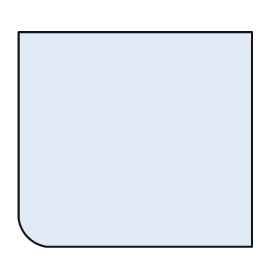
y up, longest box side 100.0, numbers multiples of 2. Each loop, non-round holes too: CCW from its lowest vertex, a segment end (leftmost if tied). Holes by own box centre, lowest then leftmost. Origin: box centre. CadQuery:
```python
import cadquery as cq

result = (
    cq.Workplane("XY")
    .moveTo(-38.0, -46.0)
    .lineTo(50.0, -46.0)
    .lineTo(50.0, 46.0)
    .lineTo(-50.0, 46.0)
    .lineTo(-50.0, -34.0)
    .threePointArc((-46.0, -42.0), (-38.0, -46.0))
    .close()
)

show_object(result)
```